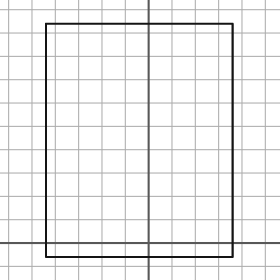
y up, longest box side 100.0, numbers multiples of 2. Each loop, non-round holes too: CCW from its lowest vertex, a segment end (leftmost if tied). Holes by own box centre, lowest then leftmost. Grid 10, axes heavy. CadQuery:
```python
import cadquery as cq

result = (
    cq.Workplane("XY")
    .moveTo(-44.0, -6.0)
    .lineTo(36.0, -6.0)
    .lineTo(36.0, 94.0)
    .lineTo(-44.0, 94.0)
    .close()
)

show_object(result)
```